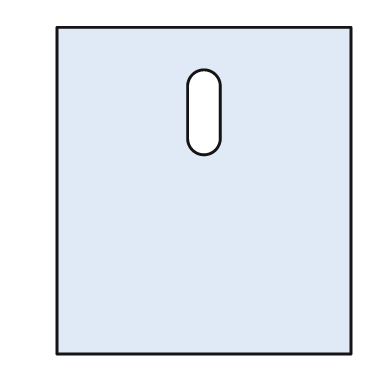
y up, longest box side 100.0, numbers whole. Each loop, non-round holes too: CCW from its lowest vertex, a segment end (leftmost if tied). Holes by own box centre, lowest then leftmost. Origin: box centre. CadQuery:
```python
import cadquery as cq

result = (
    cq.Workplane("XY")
    .moveTo(-45.0, -50.0)
    .lineTo(45.0, -50.0)
    .lineTo(45.0, 50.0)
    .lineTo(-45.0, 50.0)
    .close()
    .moveTo(-5.0, 16.0)
    .threePointArc((0.0, 11.0), (5.0, 16.0))
    .lineTo(5.0, 32.0)
    .threePointArc((0.0, 37.0), (-5.0, 32.0))
    .close()
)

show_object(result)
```